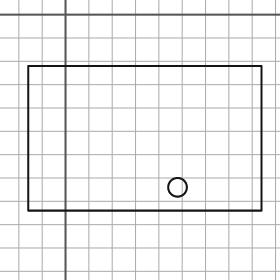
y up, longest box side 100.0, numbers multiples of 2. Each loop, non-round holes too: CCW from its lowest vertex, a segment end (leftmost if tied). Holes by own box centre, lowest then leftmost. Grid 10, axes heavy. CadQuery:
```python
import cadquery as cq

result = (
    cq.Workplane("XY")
    .moveTo(-16.0, -84.0)
    .lineTo(84.0, -84.0)
    .lineTo(84.0, -22.0)
    .lineTo(-16.0, -22.0)
    .close()
    .moveTo(48.0, -74.0)
    .circle(4.0)
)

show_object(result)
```